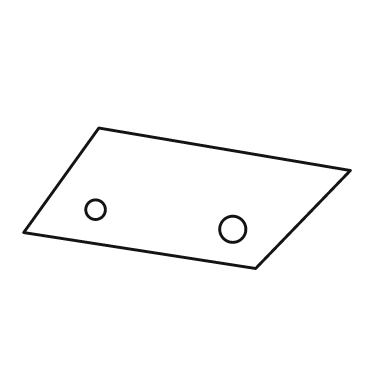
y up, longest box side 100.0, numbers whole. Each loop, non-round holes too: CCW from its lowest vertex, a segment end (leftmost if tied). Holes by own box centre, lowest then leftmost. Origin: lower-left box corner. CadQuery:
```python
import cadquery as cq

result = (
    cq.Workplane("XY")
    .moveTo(71.0, 0.0)
    .lineTo(100.0, 30.0)
    .lineTo(23.0, 43.0)
    .lineTo(0.0, 11.0)
    .close()
    .moveTo(64.0, 12.0)
    .circle(4.0)
    .moveTo(22.0, 18.0)
    .circle(3.0)
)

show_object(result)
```